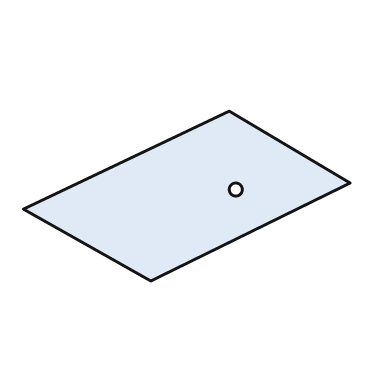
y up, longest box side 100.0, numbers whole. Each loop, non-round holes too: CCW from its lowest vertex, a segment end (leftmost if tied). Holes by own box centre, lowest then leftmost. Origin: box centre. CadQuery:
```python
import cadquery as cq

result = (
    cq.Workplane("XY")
    .moveTo(-11.0, -26.0)
    .lineTo(50.0, 4.0)
    .lineTo(13.0, 26.0)
    .lineTo(-50.0, -4.0)
    .close()
    .moveTo(15.0, 2.0)
    .circle(2.0)
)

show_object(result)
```